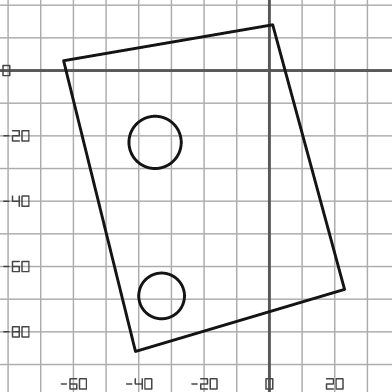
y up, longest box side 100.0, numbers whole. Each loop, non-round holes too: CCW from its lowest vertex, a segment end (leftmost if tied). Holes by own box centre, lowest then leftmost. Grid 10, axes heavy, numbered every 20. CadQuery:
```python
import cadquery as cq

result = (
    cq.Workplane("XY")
    .moveTo(-41.0, -86.0)
    .lineTo(23.0, -67.0)
    .lineTo(1.0, 14.0)
    .lineTo(-63.0, 3.0)
    .close()
    .moveTo(-33.0, -69.0)
    .circle(7.0)
    .moveTo(-35.0, -22.0)
    .circle(8.0)
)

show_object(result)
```